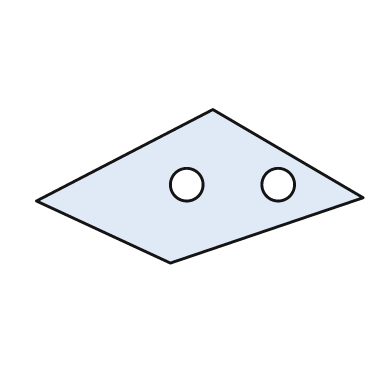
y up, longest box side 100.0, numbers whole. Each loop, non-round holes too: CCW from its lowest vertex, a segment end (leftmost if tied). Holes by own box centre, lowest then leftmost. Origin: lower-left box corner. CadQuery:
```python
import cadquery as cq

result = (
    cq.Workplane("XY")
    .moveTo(41.0, 0.0)
    .lineTo(100.0, 20.0)
    .lineTo(54.0, 47.0)
    .lineTo(0.0, 19.0)
    .close()
    .moveTo(46.0, 24.0)
    .circle(5.0)
    .moveTo(74.0, 24.0)
    .circle(5.0)
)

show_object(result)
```